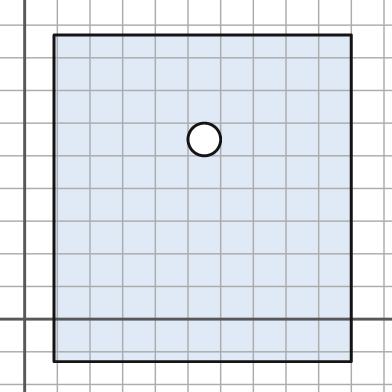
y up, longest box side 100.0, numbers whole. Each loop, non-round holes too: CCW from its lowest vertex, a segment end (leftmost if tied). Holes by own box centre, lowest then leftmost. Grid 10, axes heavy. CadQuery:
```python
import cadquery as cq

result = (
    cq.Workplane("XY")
    .moveTo(9.0, -13.0)
    .lineTo(100.0, -13.0)
    .lineTo(100.0, 87.0)
    .lineTo(9.0, 87.0)
    .close()
    .moveTo(55.0, 55.0)
    .circle(5.0)
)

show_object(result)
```